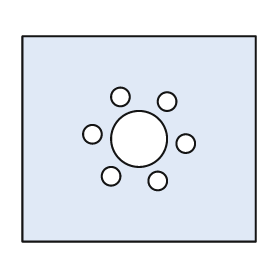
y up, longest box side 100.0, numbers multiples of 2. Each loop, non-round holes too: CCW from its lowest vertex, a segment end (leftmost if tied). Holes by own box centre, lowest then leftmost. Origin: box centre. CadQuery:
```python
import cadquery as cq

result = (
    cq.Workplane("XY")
    .moveTo(-50.0, -44.0)
    .lineTo(50.0, -44.0)
    .lineTo(50.0, 44.0)
    .lineTo(-50.0, 44.0)
    .close()
    .moveTo(8.0, -18.0)
    .circle(4.0)
    .moveTo(-12.0, -16.0)
    .circle(4.0)
    .moveTo(20.0, -2.0)
    .circle(4.0)
    .moveTo(0.0, 0.0)
    .circle(12.0)
    .moveTo(-20.0, 2.0)
    .circle(4.0)
    .moveTo(12.0, 16.0)
    .circle(4.0)
    .moveTo(-8.0, 18.0)
    .circle(4.0)
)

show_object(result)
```